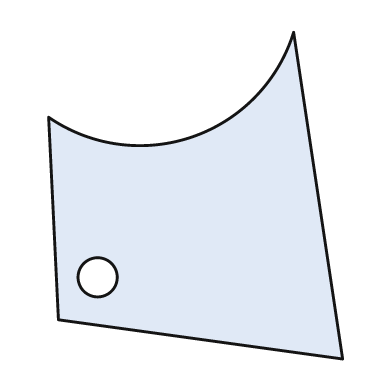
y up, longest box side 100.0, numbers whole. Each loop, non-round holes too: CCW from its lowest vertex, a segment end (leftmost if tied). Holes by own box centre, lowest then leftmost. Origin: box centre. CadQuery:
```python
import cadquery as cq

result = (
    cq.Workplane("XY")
    .moveTo(45.0, -50.0)
    .lineTo(30.0, 50.0)
    .threePointArc((-1.0, 18.0), (-45.0, 24.0))
    .lineTo(-42.0, -38.0)
    .close()
    .moveTo(-30.0, -25.0)
    .circle(6.0)
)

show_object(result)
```